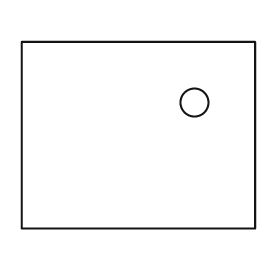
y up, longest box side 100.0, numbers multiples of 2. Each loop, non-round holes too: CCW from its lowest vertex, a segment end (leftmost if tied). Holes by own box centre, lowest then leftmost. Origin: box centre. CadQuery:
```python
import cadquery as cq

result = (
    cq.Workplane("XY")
    .moveTo(-50.0, -40.0)
    .lineTo(50.0, -40.0)
    .lineTo(50.0, 40.0)
    .lineTo(-50.0, 40.0)
    .close()
    .moveTo(24.0, 14.0)
    .circle(6.0)
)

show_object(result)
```